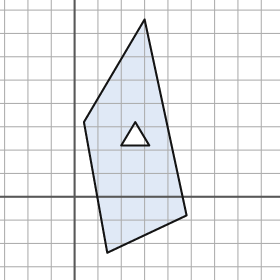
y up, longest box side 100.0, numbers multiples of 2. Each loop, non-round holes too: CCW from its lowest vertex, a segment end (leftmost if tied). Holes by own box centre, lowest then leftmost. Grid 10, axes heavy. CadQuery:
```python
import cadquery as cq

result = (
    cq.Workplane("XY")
    .moveTo(14.0, -24.0)
    .lineTo(48.0, -8.0)
    .lineTo(30.0, 76.0)
    .lineTo(4.0, 32.0)
    .close()
    .moveTo(20.0, 22.0)
    .lineTo(32.0, 22.0)
    .lineTo(26.0, 32.0)
    .close()
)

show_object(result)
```